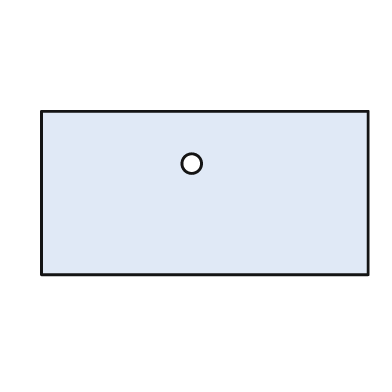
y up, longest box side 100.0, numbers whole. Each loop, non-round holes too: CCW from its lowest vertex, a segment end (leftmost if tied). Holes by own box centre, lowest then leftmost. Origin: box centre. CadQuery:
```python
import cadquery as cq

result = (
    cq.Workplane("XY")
    .moveTo(-50.0, -25.0)
    .lineTo(50.0, -25.0)
    .lineTo(50.0, 25.0)
    .lineTo(-50.0, 25.0)
    .close()
    .moveTo(-4.0, 9.0)
    .circle(3.0)
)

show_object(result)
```